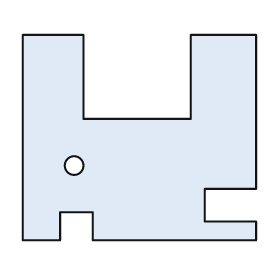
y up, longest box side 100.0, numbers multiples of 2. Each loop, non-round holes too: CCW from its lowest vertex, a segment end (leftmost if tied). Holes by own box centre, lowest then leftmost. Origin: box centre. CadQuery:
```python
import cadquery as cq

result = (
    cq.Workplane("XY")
    .moveTo(-50.0, -44.0)
    .lineTo(-34.0, -44.0)
    .lineTo(-34.0, -32.0)
    .lineTo(-20.0, -32.0)
    .lineTo(-20.0, -44.0)
    .lineTo(50.0, -44.0)
    .lineTo(50.0, -36.0)
    .lineTo(28.0, -36.0)
    .lineTo(28.0, -22.0)
    .lineTo(50.0, -22.0)
    .lineTo(50.0, 44.0)
    .lineTo(22.0, 44.0)
    .lineTo(22.0, 8.0)
    .lineTo(-24.0, 8.0)
    .lineTo(-24.0, 44.0)
    .lineTo(-50.0, 44.0)
    .close()
    .moveTo(-28.0, -12.0)
    .circle(4.0)
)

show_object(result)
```